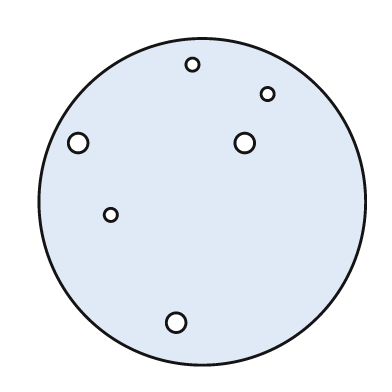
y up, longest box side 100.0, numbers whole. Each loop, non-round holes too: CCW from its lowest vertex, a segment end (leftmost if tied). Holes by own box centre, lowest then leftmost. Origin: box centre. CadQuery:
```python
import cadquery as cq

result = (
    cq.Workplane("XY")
    .moveTo(0.0, 0.0)
    .circle(50.0)
    .moveTo(-8.0, -37.0)
    .circle(3.0)
    .moveTo(-28.0, -4.0)
    .circle(2.0)
    .moveTo(-38.0, 18.0)
    .circle(3.0)
    .moveTo(13.0, 18.0)
    .circle(3.0)
    .moveTo(20.0, 33.0)
    .circle(2.0)
    .moveTo(-3.0, 42.0)
    .circle(2.0)
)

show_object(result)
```